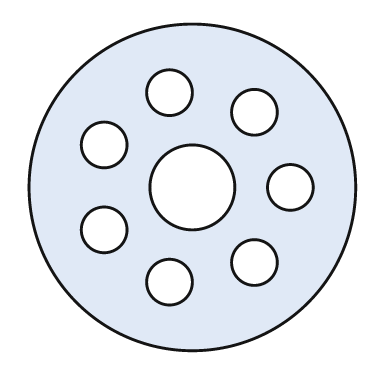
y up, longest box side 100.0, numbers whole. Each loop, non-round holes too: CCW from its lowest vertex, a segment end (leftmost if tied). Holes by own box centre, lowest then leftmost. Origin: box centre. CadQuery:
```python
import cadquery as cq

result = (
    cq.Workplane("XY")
    .moveTo(0.0, 0.0)
    .circle(50.0)
    .moveTo(-7.0, -29.0)
    .circle(7.0)
    .moveTo(19.0, -23.0)
    .circle(7.0)
    .moveTo(-27.0, -13.0)
    .circle(7.0)
    .moveTo(0.0, 0.0)
    .circle(13.0)
    .moveTo(30.0, 0.0)
    .circle(7.0)
    .moveTo(-27.0, 13.0)
    .circle(7.0)
    .moveTo(19.0, 23.0)
    .circle(7.0)
    .moveTo(-7.0, 29.0)
    .circle(7.0)
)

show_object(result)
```